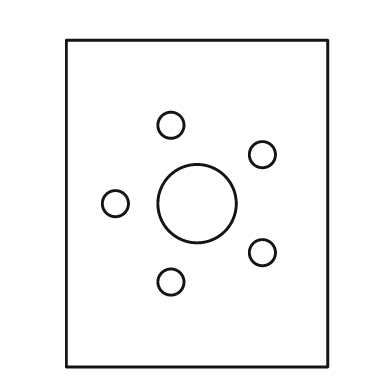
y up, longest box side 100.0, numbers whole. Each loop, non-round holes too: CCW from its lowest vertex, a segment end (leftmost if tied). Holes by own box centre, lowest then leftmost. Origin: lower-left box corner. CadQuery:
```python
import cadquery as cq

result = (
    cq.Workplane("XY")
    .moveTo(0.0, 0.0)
    .lineTo(80.0, 0.0)
    .lineTo(80.0, 100.0)
    .lineTo(0.0, 100.0)
    .close()
    .moveTo(32.0, 26.0)
    .circle(4.0)
    .moveTo(60.0, 35.0)
    .circle(4.0)
    .moveTo(15.0, 50.0)
    .circle(4.0)
    .moveTo(40.0, 50.0)
    .circle(12.0)
    .moveTo(60.0, 65.0)
    .circle(4.0)
    .moveTo(32.0, 74.0)
    .circle(4.0)
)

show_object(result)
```